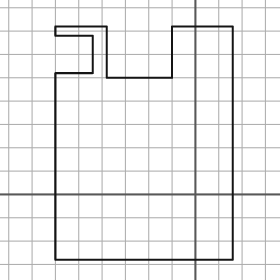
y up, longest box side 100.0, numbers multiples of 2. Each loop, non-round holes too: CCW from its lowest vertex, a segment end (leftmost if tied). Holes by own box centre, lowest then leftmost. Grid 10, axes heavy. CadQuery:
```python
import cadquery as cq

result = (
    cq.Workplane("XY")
    .moveTo(-60.0, -28.0)
    .lineTo(16.0, -28.0)
    .lineTo(16.0, 72.0)
    .lineTo(-10.0, 72.0)
    .lineTo(-10.0, 50.0)
    .lineTo(-38.0, 50.0)
    .lineTo(-38.0, 72.0)
    .lineTo(-60.0, 72.0)
    .lineTo(-60.0, 68.0)
    .lineTo(-44.0, 68.0)
    .lineTo(-44.0, 52.0)
    .lineTo(-60.0, 52.0)
    .close()
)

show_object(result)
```